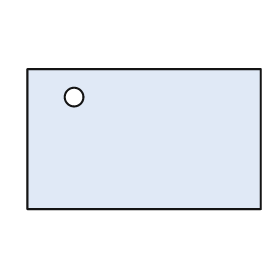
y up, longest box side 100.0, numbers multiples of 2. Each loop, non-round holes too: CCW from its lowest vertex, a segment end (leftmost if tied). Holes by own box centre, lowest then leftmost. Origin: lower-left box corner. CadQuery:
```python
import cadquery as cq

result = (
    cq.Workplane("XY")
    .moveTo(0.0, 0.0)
    .lineTo(100.0, 0.0)
    .lineTo(100.0, 60.0)
    .lineTo(0.0, 60.0)
    .close()
    .moveTo(20.0, 48.0)
    .circle(4.0)
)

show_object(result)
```